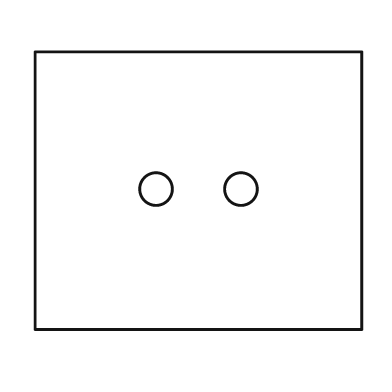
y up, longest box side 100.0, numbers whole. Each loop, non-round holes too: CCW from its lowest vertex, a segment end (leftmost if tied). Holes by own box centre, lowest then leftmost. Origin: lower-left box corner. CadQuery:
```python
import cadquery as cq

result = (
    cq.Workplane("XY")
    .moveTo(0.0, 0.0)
    .lineTo(100.0, 0.0)
    .lineTo(100.0, 85.0)
    .lineTo(0.0, 85.0)
    .close()
    .moveTo(37.0, 43.0)
    .circle(5.0)
    .moveTo(63.0, 43.0)
    .circle(5.0)
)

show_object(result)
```